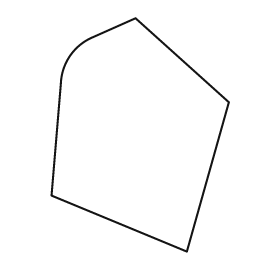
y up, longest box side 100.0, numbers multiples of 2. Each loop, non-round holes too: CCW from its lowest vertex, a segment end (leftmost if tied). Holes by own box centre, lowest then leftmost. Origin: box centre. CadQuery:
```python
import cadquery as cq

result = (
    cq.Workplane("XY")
    .moveTo(20.0, -50.0)
    .lineTo(38.0, 14.0)
    .lineTo(-2.0, 50.0)
    .lineTo(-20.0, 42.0)
    .threePointArc((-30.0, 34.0), (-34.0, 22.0))
    .lineTo(-38.0, -26.0)
    .close()
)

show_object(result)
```